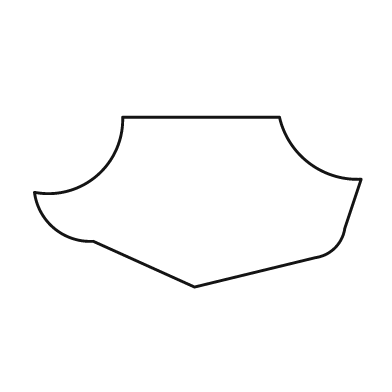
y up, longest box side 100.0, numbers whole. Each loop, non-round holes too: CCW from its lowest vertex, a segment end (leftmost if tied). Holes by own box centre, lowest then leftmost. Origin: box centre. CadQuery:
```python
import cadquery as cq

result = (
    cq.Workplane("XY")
    .moveTo(-1.0, -26.0)
    .lineTo(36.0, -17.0)
    .threePointArc((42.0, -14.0), (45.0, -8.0))
    .lineTo(50.0, 7.0)
    .threePointArc((34.0, 12.0), (25.0, 26.0))
    .lineTo(-23.0, 26.0)
    .threePointArc((-31.0, 8.0), (-50.0, 3.0))
    .threePointArc((-44.0, -8.0), (-32.0, -12.0))
    .close()
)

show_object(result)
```